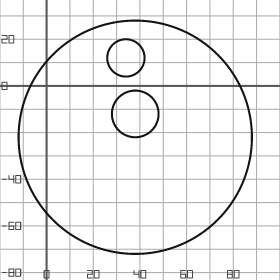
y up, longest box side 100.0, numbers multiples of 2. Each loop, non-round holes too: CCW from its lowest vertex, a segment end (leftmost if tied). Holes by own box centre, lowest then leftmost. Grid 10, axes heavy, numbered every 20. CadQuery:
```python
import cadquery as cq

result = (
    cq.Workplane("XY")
    .moveTo(38.0, -22.0)
    .circle(50.0)
    .moveTo(38.0, -12.0)
    .circle(10.0)
    .moveTo(34.0, 12.0)
    .circle(8.0)
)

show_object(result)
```